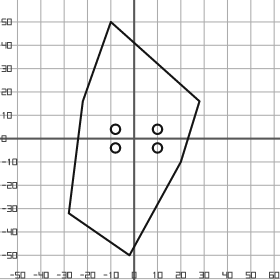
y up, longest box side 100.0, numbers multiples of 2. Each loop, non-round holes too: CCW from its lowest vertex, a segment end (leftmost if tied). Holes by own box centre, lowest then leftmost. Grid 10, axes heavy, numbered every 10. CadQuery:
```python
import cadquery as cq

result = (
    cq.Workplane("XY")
    .moveTo(-2.0, -50.0)
    .lineTo(20.0, -10.0)
    .lineTo(28.0, 16.0)
    .lineTo(-10.0, 50.0)
    .lineTo(-22.0, 16.0)
    .lineTo(-28.0, -32.0)
    .close()
    .moveTo(-8.0, -4.0)
    .circle(2.0)
    .moveTo(10.0, -4.0)
    .circle(2.0)
    .moveTo(-8.0, 4.0)
    .circle(2.0)
    .moveTo(10.0, 4.0)
    .circle(2.0)
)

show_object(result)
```